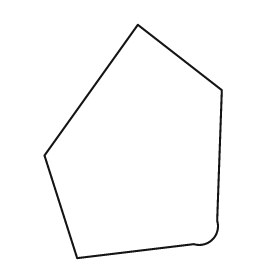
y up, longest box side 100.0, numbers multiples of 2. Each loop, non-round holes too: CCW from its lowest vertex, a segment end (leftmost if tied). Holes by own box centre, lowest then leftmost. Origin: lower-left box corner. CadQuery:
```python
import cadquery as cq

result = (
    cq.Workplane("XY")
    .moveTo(14.0, 0.0)
    .lineTo(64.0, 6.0)
    .threePointArc((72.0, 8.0), (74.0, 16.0))
    .lineTo(76.0, 72.0)
    .lineTo(40.0, 100.0)
    .lineTo(0.0, 44.0)
    .close()
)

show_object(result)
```